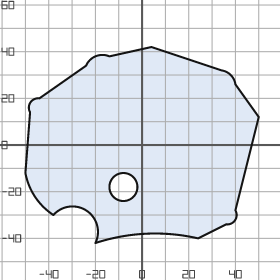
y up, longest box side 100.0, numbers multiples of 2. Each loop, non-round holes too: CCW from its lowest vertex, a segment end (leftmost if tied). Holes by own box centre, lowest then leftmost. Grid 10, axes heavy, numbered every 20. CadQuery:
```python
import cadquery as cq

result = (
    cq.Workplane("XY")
    .moveTo(-20.0, -42.0)
    .threePointArc((2.0, -38.0), (24.0, -40.0))
    .lineTo(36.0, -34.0)
    .threePointArc((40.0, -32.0), (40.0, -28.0))
    .lineTo(50.0, 12.0)
    .lineTo(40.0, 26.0)
    .threePointArc((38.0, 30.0), (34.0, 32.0))
    .lineTo(4.0, 42.0)
    .lineTo(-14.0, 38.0)
    .threePointArc((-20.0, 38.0), (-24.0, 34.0))
    .lineTo(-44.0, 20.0)
    .threePointArc((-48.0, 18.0), (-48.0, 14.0))
    .lineTo(-50.0, -12.0)
    .threePointArc((-46.0, -22.0), (-38.0, -30.0))
    .threePointArc((-24.0, -28.0), (-20.0, -42.0))
    .close()
    .moveTo(-8.0, -18.0)
    .circle(6.0)
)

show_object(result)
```